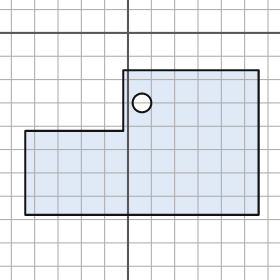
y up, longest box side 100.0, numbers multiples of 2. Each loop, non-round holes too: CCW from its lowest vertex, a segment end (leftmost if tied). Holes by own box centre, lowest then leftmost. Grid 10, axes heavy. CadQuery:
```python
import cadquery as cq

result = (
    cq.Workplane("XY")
    .moveTo(-44.0, -78.0)
    .lineTo(56.0, -78.0)
    .lineTo(56.0, -16.0)
    .lineTo(-2.0, -16.0)
    .lineTo(-2.0, -42.0)
    .lineTo(-44.0, -42.0)
    .close()
    .moveTo(6.0, -30.0)
    .circle(4.0)
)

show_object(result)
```